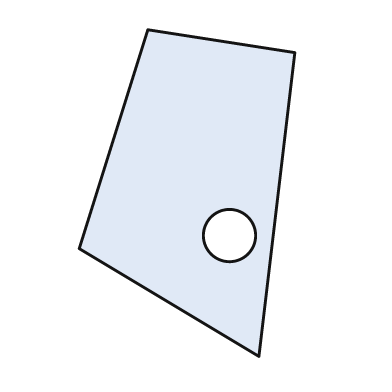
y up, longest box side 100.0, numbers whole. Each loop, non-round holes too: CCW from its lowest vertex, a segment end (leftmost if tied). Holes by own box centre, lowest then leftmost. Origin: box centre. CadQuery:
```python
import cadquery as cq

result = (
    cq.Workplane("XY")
    .moveTo(22.0, -50.0)
    .lineTo(33.0, 43.0)
    .lineTo(-12.0, 50.0)
    .lineTo(-33.0, -17.0)
    .close()
    .moveTo(13.0, -13.0)
    .circle(8.0)
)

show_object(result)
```